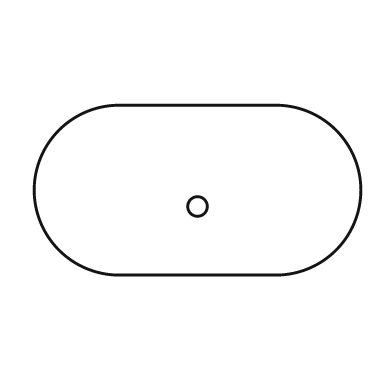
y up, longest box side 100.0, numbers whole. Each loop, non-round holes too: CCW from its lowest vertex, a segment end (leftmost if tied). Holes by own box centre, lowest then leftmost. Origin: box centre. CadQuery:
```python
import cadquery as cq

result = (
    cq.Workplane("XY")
    .moveTo(-24.0, -26.0)
    .lineTo(24.0, -26.0)
    .threePointArc((50.0, 0.0), (24.0, 26.0))
    .lineTo(-24.0, 26.0)
    .threePointArc((-50.0, 0.0), (-24.0, -26.0))
    .close()
    .moveTo(0.0, -5.0)
    .circle(3.0)
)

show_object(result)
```